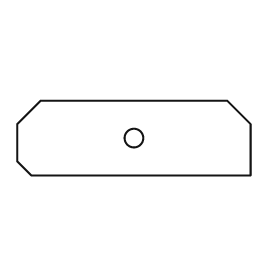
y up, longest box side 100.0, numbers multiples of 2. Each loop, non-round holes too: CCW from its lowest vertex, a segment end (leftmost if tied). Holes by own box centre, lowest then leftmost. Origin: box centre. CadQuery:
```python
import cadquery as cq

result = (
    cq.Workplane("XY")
    .moveTo(-44.0, -16.0)
    .lineTo(50.0, -16.0)
    .lineTo(50.0, 6.0)
    .lineTo(40.0, 16.0)
    .lineTo(-40.0, 16.0)
    .lineTo(-50.0, 6.0)
    .lineTo(-50.0, -10.0)
    .close()
    .moveTo(0.0, 0.0)
    .circle(4.0)
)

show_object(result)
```